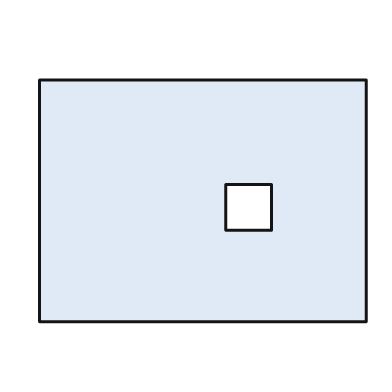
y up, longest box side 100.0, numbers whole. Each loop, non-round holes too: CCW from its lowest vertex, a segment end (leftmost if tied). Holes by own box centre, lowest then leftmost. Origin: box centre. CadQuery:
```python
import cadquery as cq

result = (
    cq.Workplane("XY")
    .moveTo(-50.0, -37.0)
    .lineTo(50.0, -37.0)
    .lineTo(50.0, 37.0)
    .lineTo(-50.0, 37.0)
    .close()
    .moveTo(7.0, -9.0)
    .lineTo(21.0, -9.0)
    .lineTo(21.0, 5.0)
    .lineTo(7.0, 5.0)
    .close()
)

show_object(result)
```